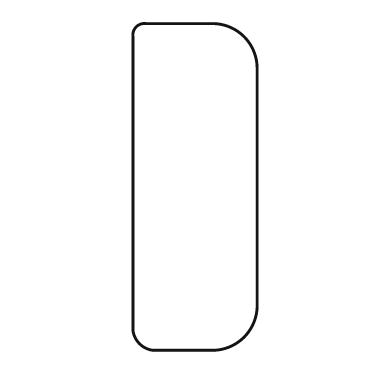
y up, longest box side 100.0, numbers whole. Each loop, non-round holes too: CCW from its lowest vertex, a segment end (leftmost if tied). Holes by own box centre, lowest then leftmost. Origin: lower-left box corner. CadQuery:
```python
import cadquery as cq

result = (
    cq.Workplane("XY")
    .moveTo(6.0, 0.0)
    .lineTo(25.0, 0.0)
    .threePointArc((34.0, 4.0), (38.0, 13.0))
    .lineTo(38.0, 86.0)
    .threePointArc((34.0, 96.0), (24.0, 100.0))
    .lineTo(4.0, 100.0)
    .threePointArc((1.0, 99.0), (0.0, 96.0))
    .lineTo(0.0, 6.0)
    .threePointArc((2.0, 2.0), (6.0, 0.0))
    .close()
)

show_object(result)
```